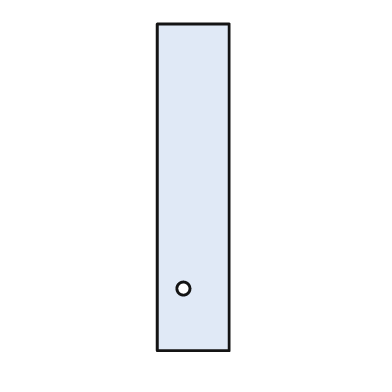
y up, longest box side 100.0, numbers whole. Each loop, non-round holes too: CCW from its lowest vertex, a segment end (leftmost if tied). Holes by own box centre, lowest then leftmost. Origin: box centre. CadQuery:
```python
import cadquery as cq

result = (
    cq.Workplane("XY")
    .moveTo(-11.0, -50.0)
    .lineTo(11.0, -50.0)
    .lineTo(11.0, 50.0)
    .lineTo(-11.0, 50.0)
    .close()
    .moveTo(-3.0, -31.0)
    .circle(2.0)
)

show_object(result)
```